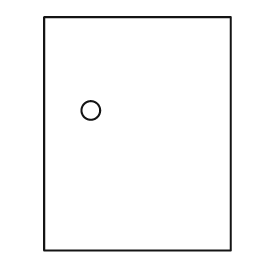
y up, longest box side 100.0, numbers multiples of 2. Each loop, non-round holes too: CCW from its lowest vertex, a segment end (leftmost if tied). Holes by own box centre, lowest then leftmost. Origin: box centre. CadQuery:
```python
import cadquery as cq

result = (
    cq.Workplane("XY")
    .moveTo(-40.0, -50.0)
    .lineTo(40.0, -50.0)
    .lineTo(40.0, 50.0)
    .lineTo(-40.0, 50.0)
    .close()
    .moveTo(-20.0, 10.0)
    .circle(4.0)
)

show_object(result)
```